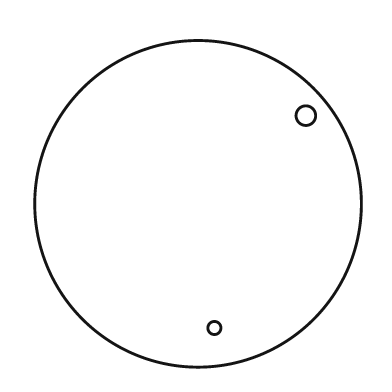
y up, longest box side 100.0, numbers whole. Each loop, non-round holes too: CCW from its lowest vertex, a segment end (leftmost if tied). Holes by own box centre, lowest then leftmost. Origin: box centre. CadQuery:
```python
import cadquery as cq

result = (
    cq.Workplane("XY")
    .moveTo(0.0, 0.0)
    .circle(50.0)
    .moveTo(5.0, -38.0)
    .circle(2.0)
    .moveTo(33.0, 27.0)
    .circle(3.0)
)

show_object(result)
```